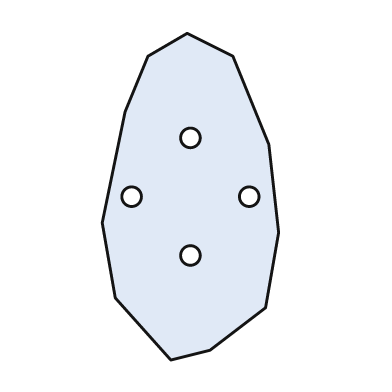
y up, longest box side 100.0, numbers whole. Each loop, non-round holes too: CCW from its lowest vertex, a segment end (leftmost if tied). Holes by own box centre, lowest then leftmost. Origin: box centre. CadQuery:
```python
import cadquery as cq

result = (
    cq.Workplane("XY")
    .moveTo(-6.0, -50.0)
    .lineTo(6.0, -47.0)
    .lineTo(23.0, -34.0)
    .lineTo(27.0, -11.0)
    .lineTo(24.0, 16.0)
    .lineTo(13.0, 43.0)
    .lineTo(-1.0, 50.0)
    .lineTo(-13.0, 43.0)
    .lineTo(-20.0, 26.0)
    .lineTo(-27.0, -8.0)
    .lineTo(-23.0, -31.0)
    .close()
    .moveTo(0.0, -18.0)
    .circle(3.0)
    .moveTo(-18.0, 0.0)
    .circle(3.0)
    .moveTo(18.0, 0.0)
    .circle(3.0)
    .moveTo(0.0, 18.0)
    .circle(3.0)
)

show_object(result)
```